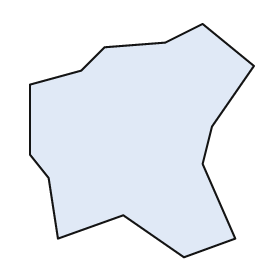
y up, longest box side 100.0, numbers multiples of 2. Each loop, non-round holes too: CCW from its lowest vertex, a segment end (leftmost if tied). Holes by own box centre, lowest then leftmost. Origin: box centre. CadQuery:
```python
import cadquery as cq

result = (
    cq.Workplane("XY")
    .moveTo(18.0, -50.0)
    .lineTo(40.0, -42.0)
    .lineTo(26.0, -10.0)
    .lineTo(30.0, 6.0)
    .lineTo(48.0, 32.0)
    .lineTo(26.0, 50.0)
    .lineTo(10.0, 42.0)
    .lineTo(-16.0, 40.0)
    .lineTo(-26.0, 30.0)
    .lineTo(-48.0, 24.0)
    .lineTo(-48.0, -6.0)
    .lineTo(-40.0, -16.0)
    .lineTo(-36.0, -42.0)
    .lineTo(-8.0, -32.0)
    .close()
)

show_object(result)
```